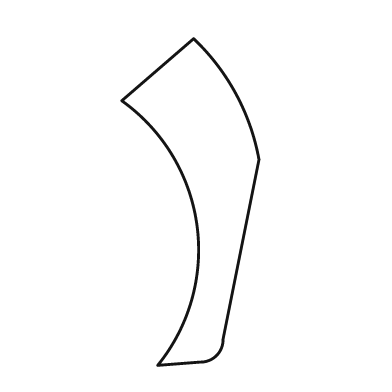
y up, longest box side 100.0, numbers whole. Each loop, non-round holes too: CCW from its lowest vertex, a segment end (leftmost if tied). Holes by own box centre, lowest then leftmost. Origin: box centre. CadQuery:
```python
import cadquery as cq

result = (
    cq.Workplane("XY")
    .moveTo(-10.0, -50.0)
    .lineTo(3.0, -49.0)
    .threePointArc((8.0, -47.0), (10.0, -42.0))
    .lineTo(21.0, 13.0)
    .threePointArc((14.0, 33.0), (1.0, 50.0))
    .lineTo(-21.0, 31.0)
    .threePointArc((2.0, -7.0), (-10.0, -50.0))
    .close()
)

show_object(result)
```